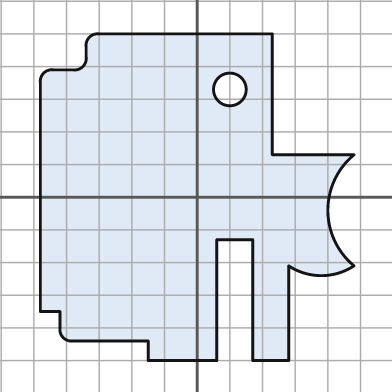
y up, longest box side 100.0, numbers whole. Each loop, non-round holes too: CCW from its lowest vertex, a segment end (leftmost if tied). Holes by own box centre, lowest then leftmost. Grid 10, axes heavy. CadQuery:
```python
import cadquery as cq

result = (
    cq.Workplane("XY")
    .moveTo(-15.0, -50.0)
    .lineTo(6.0, -50.0)
    .lineTo(6.0, -13.0)
    .lineTo(17.0, -13.0)
    .lineTo(17.0, -50.0)
    .lineTo(28.0, -50.0)
    .lineTo(28.0, -21.0)
    .threePointArc((38.0, -24.0), (48.0, -21.0))
    .threePointArc((40.0, -4.0), (48.0, 13.0))
    .lineTo(23.0, 13.0)
    .lineTo(23.0, 50.0)
    .lineTo(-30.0, 50.0)
    .threePointArc((-33.0, 49.0), (-34.0, 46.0))
    .lineTo(-34.0, 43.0)
    .threePointArc((-35.0, 40.0), (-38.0, 39.0))
    .lineTo(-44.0, 39.0)
    .threePointArc((-47.0, 38.0), (-48.0, 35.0))
    .lineTo(-48.0, -35.0)
    .lineTo(-42.0, -35.0)
    .lineTo(-42.0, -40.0)
    .threePointArc((-41.0, -43.0), (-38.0, -44.0))
    .lineTo(-15.0, -44.0)
    .close()
    .moveTo(10.0, 33.0)
    .circle(5.0)
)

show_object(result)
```